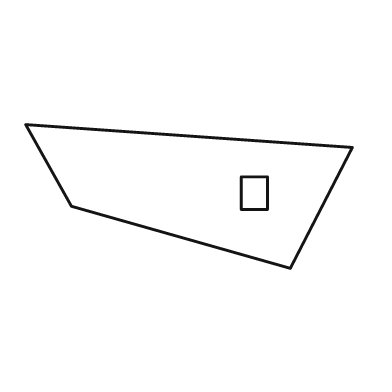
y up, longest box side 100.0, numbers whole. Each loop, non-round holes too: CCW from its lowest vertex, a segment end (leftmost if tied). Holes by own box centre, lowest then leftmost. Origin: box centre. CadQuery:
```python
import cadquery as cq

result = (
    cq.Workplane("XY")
    .moveTo(31.0, -22.0)
    .lineTo(50.0, 15.0)
    .lineTo(-50.0, 22.0)
    .lineTo(-36.0, -3.0)
    .close()
    .moveTo(16.0, -4.0)
    .lineTo(24.0, -4.0)
    .lineTo(24.0, 6.0)
    .lineTo(16.0, 6.0)
    .close()
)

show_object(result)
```